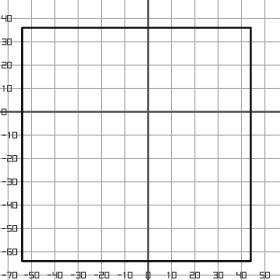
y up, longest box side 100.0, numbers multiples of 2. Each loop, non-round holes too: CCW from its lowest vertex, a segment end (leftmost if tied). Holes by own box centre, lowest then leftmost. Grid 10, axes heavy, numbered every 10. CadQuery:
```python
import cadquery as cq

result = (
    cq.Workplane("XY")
    .moveTo(-54.0, -64.0)
    .lineTo(44.0, -64.0)
    .lineTo(44.0, 36.0)
    .lineTo(-54.0, 36.0)
    .close()
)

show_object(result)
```